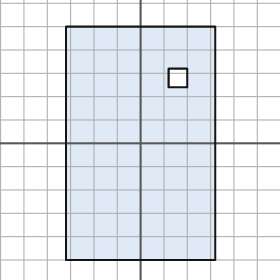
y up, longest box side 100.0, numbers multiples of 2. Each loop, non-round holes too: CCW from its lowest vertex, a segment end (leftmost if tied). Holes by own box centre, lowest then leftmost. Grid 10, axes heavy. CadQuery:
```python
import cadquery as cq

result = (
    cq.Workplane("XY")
    .moveTo(-32.0, -50.0)
    .lineTo(32.0, -50.0)
    .lineTo(32.0, 50.0)
    .lineTo(-32.0, 50.0)
    .close()
    .moveTo(12.0, 24.0)
    .lineTo(20.0, 24.0)
    .lineTo(20.0, 32.0)
    .lineTo(12.0, 32.0)
    .close()
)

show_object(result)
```